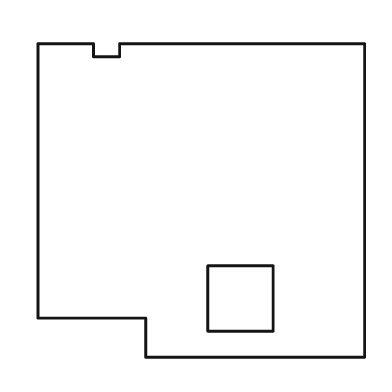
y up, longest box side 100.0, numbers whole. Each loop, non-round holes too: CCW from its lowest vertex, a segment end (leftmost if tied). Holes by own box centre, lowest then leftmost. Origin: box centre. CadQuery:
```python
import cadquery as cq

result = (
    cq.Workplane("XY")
    .moveTo(-17.0, -48.0)
    .lineTo(50.0, -48.0)
    .lineTo(50.0, 48.0)
    .lineTo(-25.0, 48.0)
    .lineTo(-25.0, 44.0)
    .lineTo(-33.0, 44.0)
    .lineTo(-33.0, 48.0)
    .lineTo(-50.0, 48.0)
    .lineTo(-50.0, -36.0)
    .lineTo(-17.0, -36.0)
    .close()
    .moveTo(2.0, -40.0)
    .lineTo(22.0, -40.0)
    .lineTo(22.0, -20.0)
    .lineTo(2.0, -20.0)
    .close()
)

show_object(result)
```